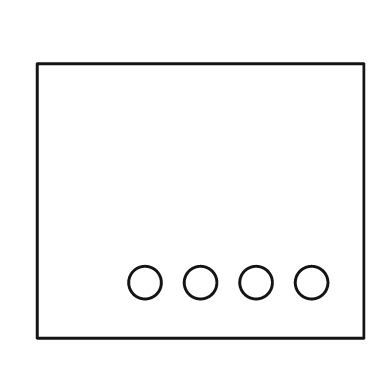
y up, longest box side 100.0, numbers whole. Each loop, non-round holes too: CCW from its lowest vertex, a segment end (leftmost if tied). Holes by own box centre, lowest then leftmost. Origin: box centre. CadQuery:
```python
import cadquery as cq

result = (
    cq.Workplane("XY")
    .moveTo(-50.0, -42.0)
    .lineTo(50.0, -42.0)
    .lineTo(50.0, 42.0)
    .lineTo(-50.0, 42.0)
    .close()
    .moveTo(-17.0, -25.0)
    .circle(5.0)
    .moveTo(0.0, -25.0)
    .circle(5.0)
    .moveTo(17.0, -25.0)
    .circle(5.0)
    .moveTo(34.0, -25.0)
    .circle(5.0)
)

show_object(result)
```